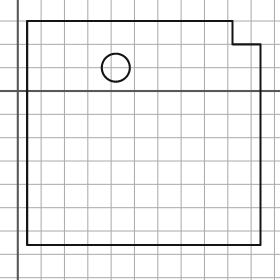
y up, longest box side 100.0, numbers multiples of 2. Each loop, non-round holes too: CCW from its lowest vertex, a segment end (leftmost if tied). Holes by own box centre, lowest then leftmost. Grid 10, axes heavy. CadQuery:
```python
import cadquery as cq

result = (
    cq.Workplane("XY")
    .moveTo(4.0, -66.0)
    .lineTo(104.0, -66.0)
    .lineTo(104.0, 20.0)
    .lineTo(92.0, 20.0)
    .lineTo(92.0, 30.0)
    .lineTo(4.0, 30.0)
    .close()
    .moveTo(42.0, 10.0)
    .circle(6.0)
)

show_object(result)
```